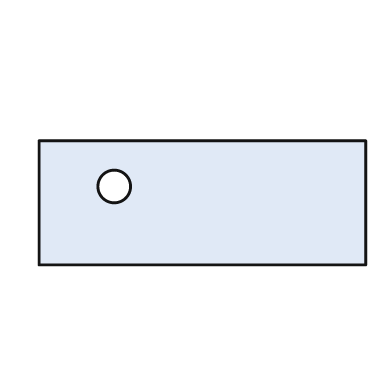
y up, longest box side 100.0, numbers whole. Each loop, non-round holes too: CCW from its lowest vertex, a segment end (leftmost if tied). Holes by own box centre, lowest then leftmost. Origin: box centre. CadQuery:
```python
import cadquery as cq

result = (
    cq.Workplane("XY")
    .moveTo(-50.0, -19.0)
    .lineTo(50.0, -19.0)
    .lineTo(50.0, 19.0)
    .lineTo(-50.0, 19.0)
    .close()
    .moveTo(-27.0, 5.0)
    .circle(5.0)
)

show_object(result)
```